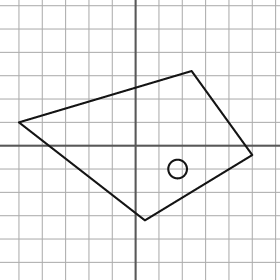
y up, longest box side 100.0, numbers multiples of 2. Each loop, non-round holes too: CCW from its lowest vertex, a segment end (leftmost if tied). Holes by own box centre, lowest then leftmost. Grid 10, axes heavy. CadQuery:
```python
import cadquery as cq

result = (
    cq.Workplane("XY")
    .moveTo(4.0, -32.0)
    .lineTo(50.0, -4.0)
    .lineTo(24.0, 32.0)
    .lineTo(-50.0, 10.0)
    .close()
    .moveTo(18.0, -10.0)
    .circle(4.0)
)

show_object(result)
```